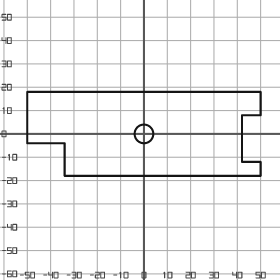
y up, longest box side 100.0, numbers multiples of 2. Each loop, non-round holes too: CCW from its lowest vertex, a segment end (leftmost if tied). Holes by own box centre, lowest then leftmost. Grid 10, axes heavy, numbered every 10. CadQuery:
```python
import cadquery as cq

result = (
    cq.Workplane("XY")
    .moveTo(-34.0, -18.0)
    .lineTo(50.0, -18.0)
    .lineTo(50.0, -12.0)
    .lineTo(42.0, -12.0)
    .lineTo(42.0, 8.0)
    .lineTo(50.0, 8.0)
    .lineTo(50.0, 18.0)
    .lineTo(-50.0, 18.0)
    .lineTo(-50.0, -4.0)
    .lineTo(-34.0, -4.0)
    .close()
    .moveTo(0.0, 0.0)
    .circle(4.0)
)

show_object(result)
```